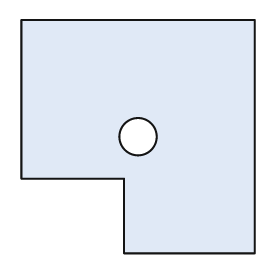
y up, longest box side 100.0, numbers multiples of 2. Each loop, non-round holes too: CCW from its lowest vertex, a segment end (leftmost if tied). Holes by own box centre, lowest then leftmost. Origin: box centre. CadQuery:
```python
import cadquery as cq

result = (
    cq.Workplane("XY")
    .moveTo(-6.0, -50.0)
    .lineTo(50.0, -50.0)
    .lineTo(50.0, 50.0)
    .lineTo(-50.0, 50.0)
    .lineTo(-50.0, -18.0)
    .lineTo(-6.0, -18.0)
    .close()
    .moveTo(0.0, 0.0)
    .circle(8.0)
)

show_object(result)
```